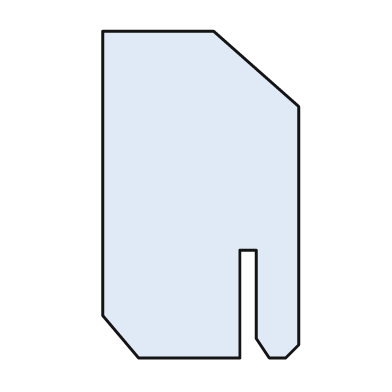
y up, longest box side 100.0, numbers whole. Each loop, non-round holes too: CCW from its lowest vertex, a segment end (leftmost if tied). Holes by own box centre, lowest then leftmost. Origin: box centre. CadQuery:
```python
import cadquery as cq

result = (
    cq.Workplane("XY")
    .moveTo(-19.0, -50.0)
    .lineTo(12.0, -50.0)
    .lineTo(12.0, -17.0)
    .lineTo(17.0, -17.0)
    .lineTo(17.0, -44.0)
    .lineTo(21.0, -50.0)
    .lineTo(26.0, -50.0)
    .lineTo(30.0, -46.0)
    .lineTo(30.0, 27.0)
    .lineTo(4.0, 50.0)
    .lineTo(-30.0, 50.0)
    .lineTo(-30.0, -37.0)
    .close()
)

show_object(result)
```